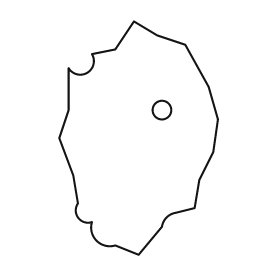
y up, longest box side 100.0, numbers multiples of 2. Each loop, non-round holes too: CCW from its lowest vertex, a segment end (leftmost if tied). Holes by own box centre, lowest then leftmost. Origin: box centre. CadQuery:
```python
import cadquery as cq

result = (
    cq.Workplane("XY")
    .moveTo(0.0, -50.0)
    .lineTo(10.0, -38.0)
    .threePointArc((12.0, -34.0), (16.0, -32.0))
    .lineTo(24.0, -30.0)
    .lineTo(26.0, -18.0)
    .lineTo(32.0, -6.0)
    .lineTo(34.0, 8.0)
    .lineTo(30.0, 22.0)
    .lineTo(20.0, 40.0)
    .lineTo(8.0, 44.0)
    .lineTo(-2.0, 50.0)
    .lineTo(-10.0, 38.0)
    .lineTo(-20.0, 36.0)
    .threePointArc((-22.0, 28.0), (-30.0, 30.0))
    .lineTo(-30.0, 12.0)
    .lineTo(-34.0, 0.0)
    .lineTo(-28.0, -16.0)
    .lineTo(-26.0, -28.0)
    .threePointArc((-26.0, -34.0), (-20.0, -36.0))
    .threePointArc((-18.0, -44.0), (-10.0, -46.0))
    .close()
    .moveTo(10.0, 12.0)
    .circle(4.0)
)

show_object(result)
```